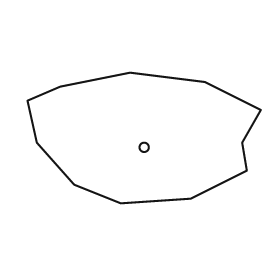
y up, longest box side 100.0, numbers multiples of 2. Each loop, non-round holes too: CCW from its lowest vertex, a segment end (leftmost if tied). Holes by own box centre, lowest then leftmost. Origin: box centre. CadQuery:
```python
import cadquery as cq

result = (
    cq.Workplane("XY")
    .moveTo(-10.0, -28.0)
    .lineTo(20.0, -26.0)
    .lineTo(44.0, -14.0)
    .lineTo(42.0, -2.0)
    .lineTo(50.0, 12.0)
    .lineTo(26.0, 24.0)
    .lineTo(-6.0, 28.0)
    .lineTo(-36.0, 22.0)
    .lineTo(-50.0, 16.0)
    .lineTo(-46.0, -2.0)
    .lineTo(-30.0, -20.0)
    .close()
    .moveTo(0.0, -4.0)
    .circle(2.0)
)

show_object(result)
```